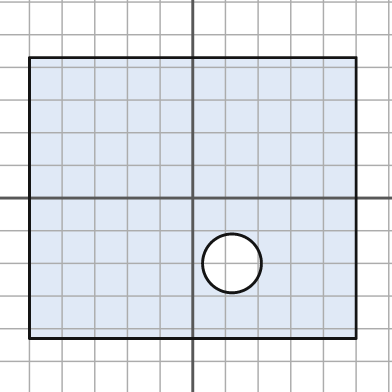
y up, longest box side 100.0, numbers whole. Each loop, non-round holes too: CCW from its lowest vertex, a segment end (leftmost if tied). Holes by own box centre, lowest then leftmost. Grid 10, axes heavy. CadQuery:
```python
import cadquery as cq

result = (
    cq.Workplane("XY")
    .moveTo(-50.0, -43.0)
    .lineTo(50.0, -43.0)
    .lineTo(50.0, 43.0)
    .lineTo(-50.0, 43.0)
    .close()
    .moveTo(12.0, -20.0)
    .circle(9.0)
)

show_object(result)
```